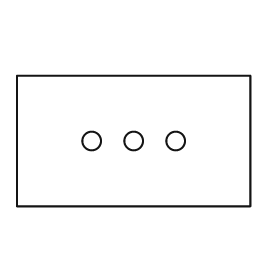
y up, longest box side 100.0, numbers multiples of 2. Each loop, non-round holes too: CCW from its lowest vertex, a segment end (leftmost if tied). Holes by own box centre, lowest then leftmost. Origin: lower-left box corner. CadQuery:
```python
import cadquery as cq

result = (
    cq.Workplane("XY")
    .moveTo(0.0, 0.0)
    .lineTo(100.0, 0.0)
    .lineTo(100.0, 56.0)
    .lineTo(0.0, 56.0)
    .close()
    .moveTo(32.0, 28.0)
    .circle(4.0)
    .moveTo(50.0, 28.0)
    .circle(4.0)
    .moveTo(68.0, 28.0)
    .circle(4.0)
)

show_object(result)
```